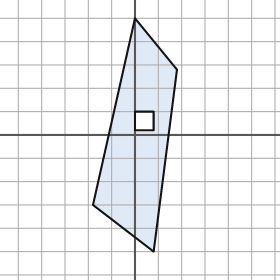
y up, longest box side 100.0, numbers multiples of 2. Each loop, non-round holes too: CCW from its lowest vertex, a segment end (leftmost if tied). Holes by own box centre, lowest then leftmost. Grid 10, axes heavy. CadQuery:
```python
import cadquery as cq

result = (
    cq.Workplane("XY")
    .moveTo(8.0, -50.0)
    .lineTo(18.0, 28.0)
    .lineTo(0.0, 50.0)
    .lineTo(-18.0, -30.0)
    .close()
    .moveTo(0.0, 2.0)
    .lineTo(8.0, 2.0)
    .lineTo(8.0, 10.0)
    .lineTo(0.0, 10.0)
    .close()
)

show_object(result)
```